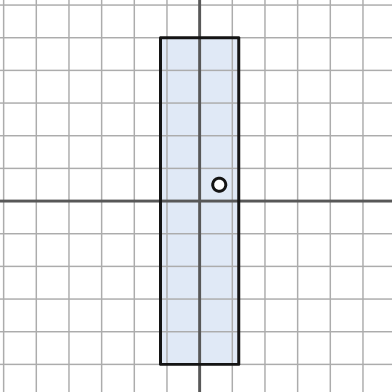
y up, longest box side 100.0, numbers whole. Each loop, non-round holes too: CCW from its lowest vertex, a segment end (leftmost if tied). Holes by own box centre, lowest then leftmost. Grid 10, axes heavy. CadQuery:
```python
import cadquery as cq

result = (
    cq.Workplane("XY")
    .moveTo(-12.0, -50.0)
    .lineTo(12.0, -50.0)
    .lineTo(12.0, 50.0)
    .lineTo(-12.0, 50.0)
    .close()
    .moveTo(6.0, 5.0)
    .circle(2.0)
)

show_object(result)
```